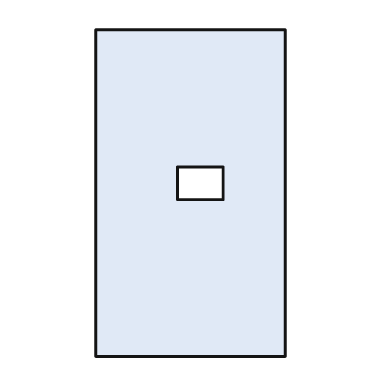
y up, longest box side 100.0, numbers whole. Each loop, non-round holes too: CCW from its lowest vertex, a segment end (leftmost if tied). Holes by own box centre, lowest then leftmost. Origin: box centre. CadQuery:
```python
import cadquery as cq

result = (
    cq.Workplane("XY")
    .moveTo(-29.0, -50.0)
    .lineTo(29.0, -50.0)
    .lineTo(29.0, 50.0)
    .lineTo(-29.0, 50.0)
    .close()
    .moveTo(-4.0, -2.0)
    .lineTo(10.0, -2.0)
    .lineTo(10.0, 8.0)
    .lineTo(-4.0, 8.0)
    .close()
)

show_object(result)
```